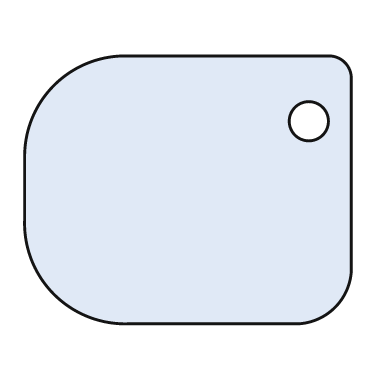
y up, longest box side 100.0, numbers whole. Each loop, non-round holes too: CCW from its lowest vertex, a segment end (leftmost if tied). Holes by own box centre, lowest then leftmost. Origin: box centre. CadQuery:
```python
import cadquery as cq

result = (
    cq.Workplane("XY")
    .moveTo(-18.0, -41.0)
    .lineTo(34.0, -41.0)
    .threePointArc((45.0, -36.0), (50.0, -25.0))
    .lineTo(50.0, 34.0)
    .threePointArc((48.0, 39.0), (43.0, 41.0))
    .lineTo(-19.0, 41.0)
    .threePointArc((-41.0, 32.0), (-50.0, 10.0))
    .lineTo(-50.0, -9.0)
    .threePointArc((-41.0, -32.0), (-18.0, -41.0))
    .close()
    .moveTo(37.0, 21.0)
    .circle(6.0)
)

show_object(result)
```